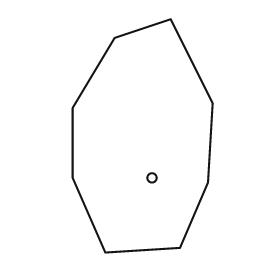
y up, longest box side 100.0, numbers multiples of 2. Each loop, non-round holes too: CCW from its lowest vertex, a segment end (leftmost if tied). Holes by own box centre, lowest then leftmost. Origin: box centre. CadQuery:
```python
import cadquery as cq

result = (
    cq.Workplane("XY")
    .moveTo(-16.0, -50.0)
    .lineTo(16.0, -48.0)
    .lineTo(28.0, -20.0)
    .lineTo(30.0, 14.0)
    .lineTo(12.0, 50.0)
    .lineTo(-12.0, 42.0)
    .lineTo(-30.0, 12.0)
    .lineTo(-30.0, -18.0)
    .close()
    .moveTo(4.0, -18.0)
    .circle(2.0)
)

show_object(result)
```